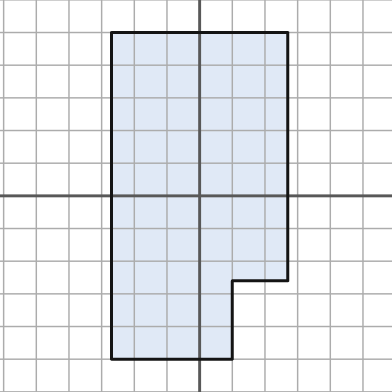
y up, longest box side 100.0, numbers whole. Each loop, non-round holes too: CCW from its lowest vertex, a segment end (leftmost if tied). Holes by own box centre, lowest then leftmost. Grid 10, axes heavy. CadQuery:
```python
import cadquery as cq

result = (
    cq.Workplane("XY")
    .moveTo(-27.0, -50.0)
    .lineTo(10.0, -50.0)
    .lineTo(10.0, -26.0)
    .lineTo(27.0, -26.0)
    .lineTo(27.0, 50.0)
    .lineTo(-27.0, 50.0)
    .close()
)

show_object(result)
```